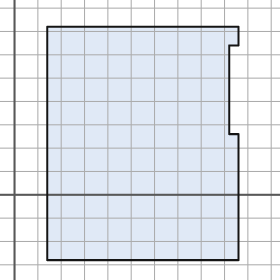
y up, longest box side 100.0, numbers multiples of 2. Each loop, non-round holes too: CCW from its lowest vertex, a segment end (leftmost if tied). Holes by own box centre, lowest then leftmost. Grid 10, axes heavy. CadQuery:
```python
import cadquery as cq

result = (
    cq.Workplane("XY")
    .moveTo(14.0, -28.0)
    .lineTo(96.0, -28.0)
    .lineTo(96.0, 26.0)
    .lineTo(92.0, 26.0)
    .lineTo(92.0, 64.0)
    .lineTo(96.0, 64.0)
    .lineTo(96.0, 72.0)
    .lineTo(14.0, 72.0)
    .close()
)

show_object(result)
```